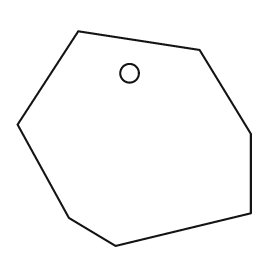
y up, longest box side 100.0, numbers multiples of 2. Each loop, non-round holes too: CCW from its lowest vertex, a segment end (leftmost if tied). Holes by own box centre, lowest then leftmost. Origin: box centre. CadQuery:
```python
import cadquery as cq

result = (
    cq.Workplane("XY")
    .moveTo(-8.0, -46.0)
    .lineTo(50.0, -32.0)
    .lineTo(50.0, 2.0)
    .lineTo(28.0, 38.0)
    .lineTo(-24.0, 46.0)
    .lineTo(-50.0, 6.0)
    .lineTo(-28.0, -34.0)
    .close()
    .moveTo(-2.0, 28.0)
    .circle(4.0)
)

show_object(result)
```